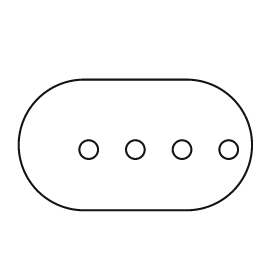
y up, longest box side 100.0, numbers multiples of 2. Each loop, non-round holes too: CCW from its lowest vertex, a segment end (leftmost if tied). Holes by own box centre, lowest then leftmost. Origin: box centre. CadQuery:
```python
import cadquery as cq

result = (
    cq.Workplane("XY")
    .moveTo(-22.0, -28.0)
    .lineTo(22.0, -28.0)
    .threePointArc((50.0, 0.0), (22.0, 28.0))
    .lineTo(-22.0, 28.0)
    .threePointArc((-50.0, 0.0), (-22.0, -28.0))
    .close()
    .moveTo(-20.0, -2.0)
    .circle(4.0)
    .moveTo(0.0, -2.0)
    .circle(4.0)
    .moveTo(20.0, -2.0)
    .circle(4.0)
    .moveTo(40.0, -2.0)
    .circle(4.0)
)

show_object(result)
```